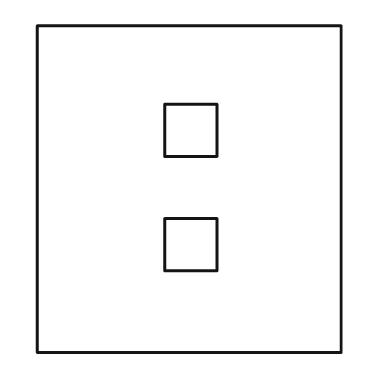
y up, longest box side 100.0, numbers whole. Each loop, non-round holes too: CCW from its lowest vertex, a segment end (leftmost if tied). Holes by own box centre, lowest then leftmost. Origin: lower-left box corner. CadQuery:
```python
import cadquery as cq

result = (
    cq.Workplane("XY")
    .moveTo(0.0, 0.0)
    .lineTo(93.0, 0.0)
    .lineTo(93.0, 100.0)
    .lineTo(0.0, 100.0)
    .close()
    .moveTo(39.0, 25.0)
    .lineTo(55.0, 25.0)
    .lineTo(55.0, 41.0)
    .lineTo(39.0, 41.0)
    .close()
    .moveTo(39.0, 60.0)
    .lineTo(55.0, 60.0)
    .lineTo(55.0, 76.0)
    .lineTo(39.0, 76.0)
    .close()
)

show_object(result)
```